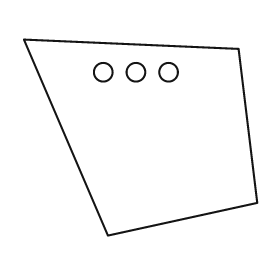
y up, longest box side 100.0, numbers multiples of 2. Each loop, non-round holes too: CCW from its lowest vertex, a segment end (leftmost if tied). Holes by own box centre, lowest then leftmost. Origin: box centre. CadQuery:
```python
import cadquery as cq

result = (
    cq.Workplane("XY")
    .moveTo(-14.0, -42.0)
    .lineTo(50.0, -28.0)
    .lineTo(42.0, 38.0)
    .lineTo(-50.0, 42.0)
    .close()
    .moveTo(-16.0, 28.0)
    .circle(4.0)
    .moveTo(-2.0, 28.0)
    .circle(4.0)
    .moveTo(12.0, 28.0)
    .circle(4.0)
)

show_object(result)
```